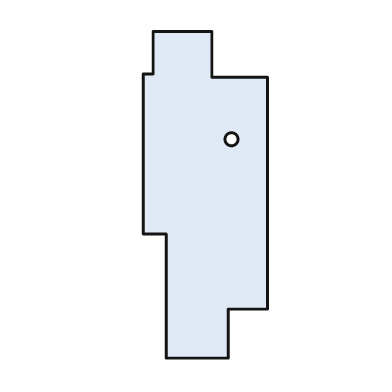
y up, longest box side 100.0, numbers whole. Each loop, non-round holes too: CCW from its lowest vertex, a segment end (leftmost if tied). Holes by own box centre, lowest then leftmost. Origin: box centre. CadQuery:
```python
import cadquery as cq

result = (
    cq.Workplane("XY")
    .moveTo(-12.0, -50.0)
    .lineTo(7.0, -50.0)
    .lineTo(7.0, -35.0)
    .lineTo(19.0, -35.0)
    .lineTo(19.0, 36.0)
    .lineTo(2.0, 36.0)
    .lineTo(2.0, 50.0)
    .lineTo(-16.0, 50.0)
    .lineTo(-16.0, 37.0)
    .lineTo(-19.0, 37.0)
    .lineTo(-19.0, -12.0)
    .lineTo(-12.0, -12.0)
    .close()
    .moveTo(8.0, 17.0)
    .circle(2.0)
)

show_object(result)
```